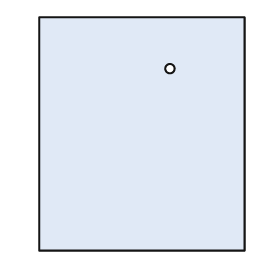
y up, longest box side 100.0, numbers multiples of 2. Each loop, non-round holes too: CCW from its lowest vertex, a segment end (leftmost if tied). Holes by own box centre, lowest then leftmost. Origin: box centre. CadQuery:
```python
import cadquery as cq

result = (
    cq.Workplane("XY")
    .moveTo(-44.0, -50.0)
    .lineTo(44.0, -50.0)
    .lineTo(44.0, 50.0)
    .lineTo(-44.0, 50.0)
    .close()
    .moveTo(12.0, 28.0)
    .circle(2.0)
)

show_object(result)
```